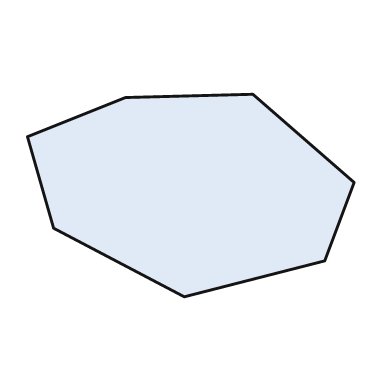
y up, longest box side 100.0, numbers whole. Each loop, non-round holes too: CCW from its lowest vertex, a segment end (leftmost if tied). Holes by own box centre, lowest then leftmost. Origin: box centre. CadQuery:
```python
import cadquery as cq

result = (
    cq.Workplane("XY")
    .moveTo(-2.0, -31.0)
    .lineTo(41.0, -20.0)
    .lineTo(50.0, 4.0)
    .lineTo(19.0, 31.0)
    .lineTo(-20.0, 30.0)
    .lineTo(-50.0, 18.0)
    .lineTo(-42.0, -10.0)
    .close()
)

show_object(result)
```